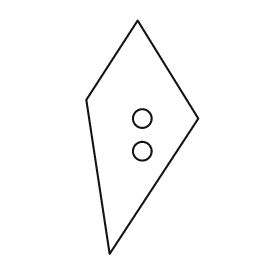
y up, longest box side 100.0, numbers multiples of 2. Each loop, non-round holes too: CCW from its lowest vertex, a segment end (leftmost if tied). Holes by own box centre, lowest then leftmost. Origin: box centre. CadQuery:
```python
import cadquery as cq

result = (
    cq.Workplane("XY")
    .moveTo(-14.0, -50.0)
    .lineTo(24.0, 8.0)
    .lineTo(-2.0, 50.0)
    .lineTo(-24.0, 16.0)
    .close()
    .moveTo(0.0, -6.0)
    .circle(4.0)
    .moveTo(0.0, 8.0)
    .circle(4.0)
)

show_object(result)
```